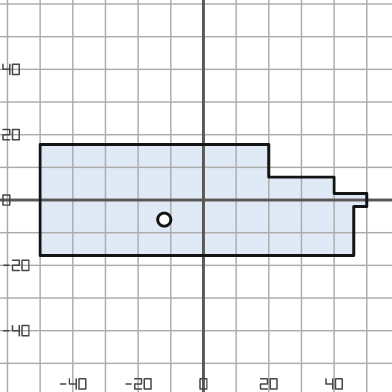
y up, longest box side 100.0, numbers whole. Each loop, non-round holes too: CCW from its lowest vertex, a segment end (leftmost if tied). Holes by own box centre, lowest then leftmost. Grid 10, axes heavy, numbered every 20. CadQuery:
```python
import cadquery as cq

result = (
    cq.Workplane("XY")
    .moveTo(-50.0, -17.0)
    .lineTo(46.0, -17.0)
    .lineTo(46.0, -2.0)
    .lineTo(50.0, -2.0)
    .lineTo(50.0, 2.0)
    .lineTo(40.0, 2.0)
    .lineTo(40.0, 7.0)
    .lineTo(20.0, 7.0)
    .lineTo(20.0, 17.0)
    .lineTo(-50.0, 17.0)
    .close()
    .moveTo(-12.0, -6.0)
    .circle(2.0)
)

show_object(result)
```